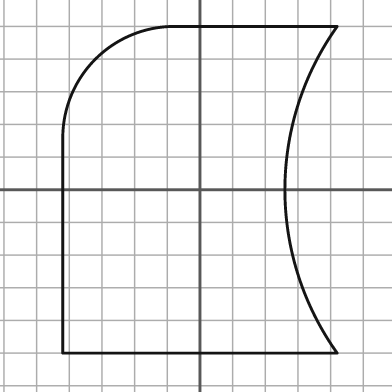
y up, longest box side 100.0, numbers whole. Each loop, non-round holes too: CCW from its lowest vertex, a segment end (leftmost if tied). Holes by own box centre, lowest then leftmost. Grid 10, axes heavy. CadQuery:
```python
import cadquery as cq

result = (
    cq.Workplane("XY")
    .moveTo(-42.0, -50.0)
    .lineTo(42.0, -50.0)
    .threePointArc((26.0, 0.0), (42.0, 50.0))
    .lineTo(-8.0, 50.0)
    .threePointArc((-32.0, 40.0), (-42.0, 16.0))
    .close()
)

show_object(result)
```